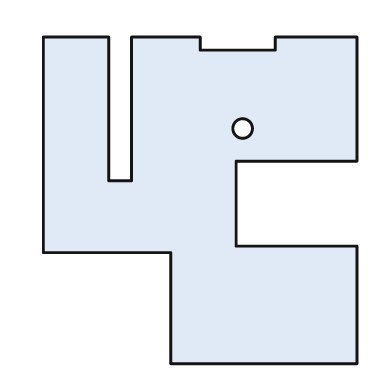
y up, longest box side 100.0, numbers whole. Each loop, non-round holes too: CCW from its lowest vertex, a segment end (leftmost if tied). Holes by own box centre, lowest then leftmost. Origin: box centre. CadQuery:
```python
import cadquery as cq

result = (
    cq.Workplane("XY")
    .moveTo(-9.0, -50.0)
    .lineTo(48.0, -50.0)
    .lineTo(48.0, -14.0)
    .lineTo(11.0, -14.0)
    .lineTo(11.0, 12.0)
    .lineTo(48.0, 12.0)
    .lineTo(48.0, 50.0)
    .lineTo(23.0, 50.0)
    .lineTo(23.0, 46.0)
    .lineTo(0.0, 46.0)
    .lineTo(0.0, 50.0)
    .lineTo(-21.0, 50.0)
    .lineTo(-21.0, 6.0)
    .lineTo(-28.0, 6.0)
    .lineTo(-28.0, 50.0)
    .lineTo(-48.0, 50.0)
    .lineTo(-48.0, -16.0)
    .lineTo(-9.0, -16.0)
    .close()
    .moveTo(13.0, 22.0)
    .circle(3.0)
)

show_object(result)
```